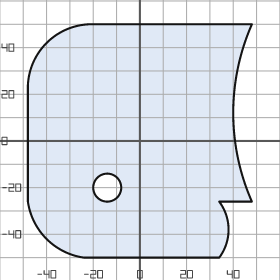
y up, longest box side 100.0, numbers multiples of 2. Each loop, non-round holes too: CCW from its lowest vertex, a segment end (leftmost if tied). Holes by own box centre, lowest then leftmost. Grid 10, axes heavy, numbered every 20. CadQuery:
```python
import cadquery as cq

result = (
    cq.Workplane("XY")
    .moveTo(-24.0, -50.0)
    .lineTo(34.0, -50.0)
    .threePointArc((38.0, -38.0), (34.0, -26.0))
    .lineTo(48.0, -26.0)
    .threePointArc((40.0, 12.0), (48.0, 50.0))
    .lineTo(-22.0, 50.0)
    .threePointArc((-40.0, 42.0), (-48.0, 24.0))
    .lineTo(-48.0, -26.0)
    .threePointArc((-40.0, -42.0), (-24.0, -50.0))
    .close()
    .moveTo(-14.0, -20.0)
    .circle(6.0)
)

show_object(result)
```